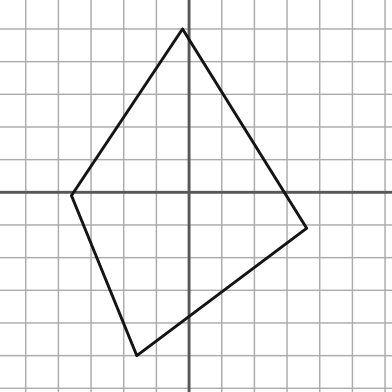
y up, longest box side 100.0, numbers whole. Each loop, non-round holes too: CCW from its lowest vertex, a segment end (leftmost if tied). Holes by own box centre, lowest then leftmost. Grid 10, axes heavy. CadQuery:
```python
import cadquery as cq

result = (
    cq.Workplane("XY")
    .moveTo(-16.0, -50.0)
    .lineTo(36.0, -11.0)
    .lineTo(-2.0, 50.0)
    .lineTo(-36.0, -1.0)
    .close()
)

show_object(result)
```